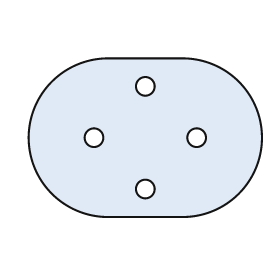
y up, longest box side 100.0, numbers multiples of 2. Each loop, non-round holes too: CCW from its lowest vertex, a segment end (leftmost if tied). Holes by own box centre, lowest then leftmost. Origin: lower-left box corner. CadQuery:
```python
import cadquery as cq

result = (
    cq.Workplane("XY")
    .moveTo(34.0, 0.0)
    .lineTo(66.0, 0.0)
    .threePointArc((100.0, 34.0), (66.0, 68.0))
    .lineTo(34.0, 68.0)
    .threePointArc((0.0, 34.0), (34.0, 0.0))
    .close()
    .moveTo(50.0, 12.0)
    .circle(4.0)
    .moveTo(28.0, 34.0)
    .circle(4.0)
    .moveTo(72.0, 34.0)
    .circle(4.0)
    .moveTo(50.0, 56.0)
    .circle(4.0)
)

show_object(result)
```